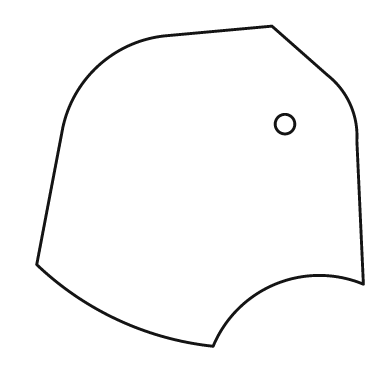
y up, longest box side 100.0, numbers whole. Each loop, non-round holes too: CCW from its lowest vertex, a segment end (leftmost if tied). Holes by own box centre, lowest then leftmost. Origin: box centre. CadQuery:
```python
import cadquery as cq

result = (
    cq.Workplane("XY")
    .moveTo(4.0, -49.0)
    .threePointArc((23.0, -30.0), (50.0, -30.0))
    .lineTo(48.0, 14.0)
    .threePointArc((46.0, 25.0), (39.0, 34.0))
    .lineTo(22.0, 49.0)
    .lineTo(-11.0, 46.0)
    .threePointArc((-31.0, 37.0), (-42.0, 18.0))
    .lineTo(-50.0, -24.0)
    .threePointArc((-25.0, -41.0), (4.0, -49.0))
    .close()
    .moveTo(26.0, 19.0)
    .circle(3.0)
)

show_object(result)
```